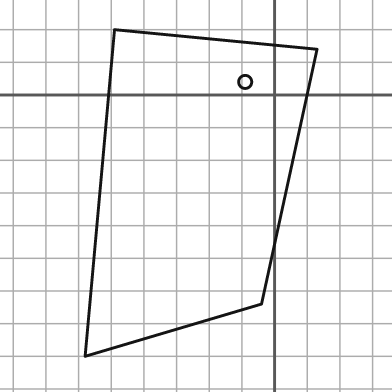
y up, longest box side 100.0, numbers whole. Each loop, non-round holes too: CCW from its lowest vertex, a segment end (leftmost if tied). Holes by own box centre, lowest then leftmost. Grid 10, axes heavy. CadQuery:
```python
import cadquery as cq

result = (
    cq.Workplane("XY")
    .moveTo(-58.0, -80.0)
    .lineTo(-4.0, -64.0)
    .lineTo(13.0, 14.0)
    .lineTo(-49.0, 20.0)
    .close()
    .moveTo(-9.0, 4.0)
    .circle(2.0)
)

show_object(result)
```